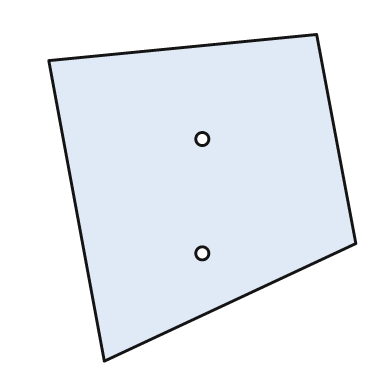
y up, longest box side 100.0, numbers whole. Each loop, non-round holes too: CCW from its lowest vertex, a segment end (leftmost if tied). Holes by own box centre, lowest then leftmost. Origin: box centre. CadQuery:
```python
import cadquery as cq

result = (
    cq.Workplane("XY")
    .moveTo(-30.0, -50.0)
    .lineTo(47.0, -14.0)
    .lineTo(35.0, 50.0)
    .lineTo(-47.0, 42.0)
    .close()
    .moveTo(0.0, -17.0)
    .circle(2.0)
    .moveTo(0.0, 18.0)
    .circle(2.0)
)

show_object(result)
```